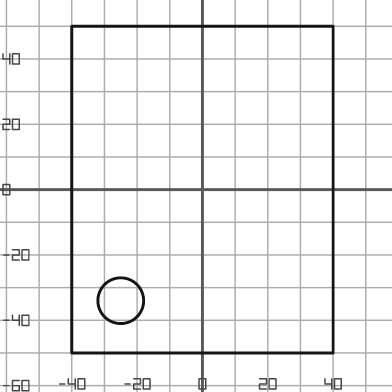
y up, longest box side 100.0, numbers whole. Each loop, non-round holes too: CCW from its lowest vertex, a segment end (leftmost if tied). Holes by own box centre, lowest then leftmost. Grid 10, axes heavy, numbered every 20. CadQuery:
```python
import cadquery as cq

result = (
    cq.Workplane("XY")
    .moveTo(-40.0, -50.0)
    .lineTo(40.0, -50.0)
    .lineTo(40.0, 50.0)
    .lineTo(-40.0, 50.0)
    .close()
    .moveTo(-25.0, -34.0)
    .circle(7.0)
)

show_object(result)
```